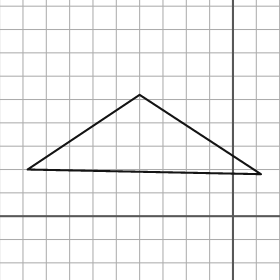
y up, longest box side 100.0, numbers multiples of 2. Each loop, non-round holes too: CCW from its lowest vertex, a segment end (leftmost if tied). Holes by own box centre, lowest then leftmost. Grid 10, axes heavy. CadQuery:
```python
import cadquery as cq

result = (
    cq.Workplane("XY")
    .moveTo(12.0, 18.0)
    .lineTo(-40.0, 52.0)
    .lineTo(-88.0, 20.0)
    .close()
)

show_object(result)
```